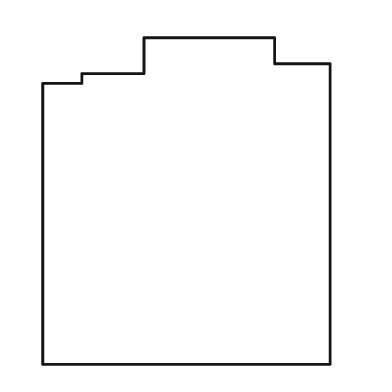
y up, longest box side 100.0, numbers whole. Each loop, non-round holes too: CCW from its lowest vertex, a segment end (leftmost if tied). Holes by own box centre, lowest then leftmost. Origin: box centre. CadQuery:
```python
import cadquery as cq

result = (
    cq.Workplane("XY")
    .moveTo(-44.0, -50.0)
    .lineTo(44.0, -50.0)
    .lineTo(44.0, 42.0)
    .lineTo(27.0, 42.0)
    .lineTo(27.0, 50.0)
    .lineTo(-13.0, 50.0)
    .lineTo(-13.0, 39.0)
    .lineTo(-32.0, 39.0)
    .lineTo(-32.0, 36.0)
    .lineTo(-44.0, 36.0)
    .close()
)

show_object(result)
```